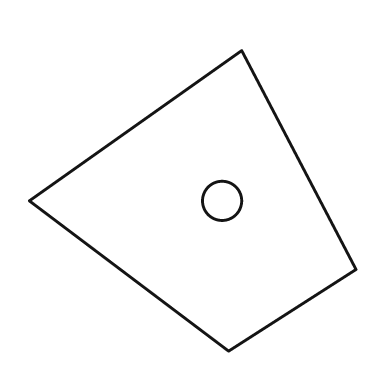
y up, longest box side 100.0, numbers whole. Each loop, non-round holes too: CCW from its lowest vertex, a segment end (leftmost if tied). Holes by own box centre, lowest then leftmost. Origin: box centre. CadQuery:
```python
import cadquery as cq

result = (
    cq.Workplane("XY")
    .moveTo(11.0, -46.0)
    .lineTo(50.0, -21.0)
    .lineTo(15.0, 46.0)
    .lineTo(-50.0, 0.0)
    .close()
    .moveTo(9.0, 0.0)
    .circle(6.0)
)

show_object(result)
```